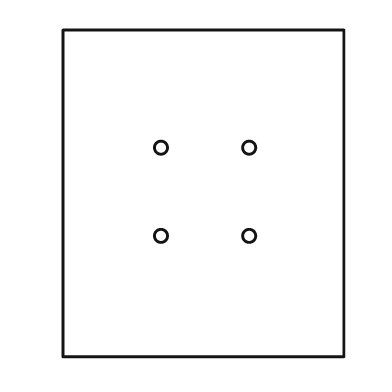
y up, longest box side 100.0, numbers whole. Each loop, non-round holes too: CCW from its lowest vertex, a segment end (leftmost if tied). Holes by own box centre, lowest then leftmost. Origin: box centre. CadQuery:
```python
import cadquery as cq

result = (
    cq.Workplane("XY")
    .moveTo(-43.0, -50.0)
    .lineTo(43.0, -50.0)
    .lineTo(43.0, 50.0)
    .lineTo(-43.0, 50.0)
    .close()
    .moveTo(-13.0, -13.0)
    .circle(2.0)
    .moveTo(14.0, -13.0)
    .circle(2.0)
    .moveTo(-13.0, 14.0)
    .circle(2.0)
    .moveTo(14.0, 14.0)
    .circle(2.0)
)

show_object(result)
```